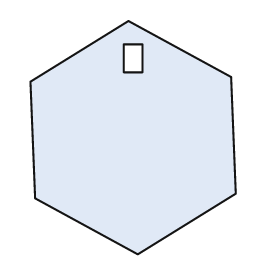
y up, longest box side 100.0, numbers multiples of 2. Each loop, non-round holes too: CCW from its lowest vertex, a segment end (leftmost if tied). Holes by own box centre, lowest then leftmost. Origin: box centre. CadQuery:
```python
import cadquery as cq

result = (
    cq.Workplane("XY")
    .moveTo(2.0, -50.0)
    .lineTo(44.0, -24.0)
    .lineTo(42.0, 26.0)
    .lineTo(-2.0, 50.0)
    .lineTo(-44.0, 24.0)
    .lineTo(-42.0, -26.0)
    .close()
    .moveTo(-4.0, 28.0)
    .lineTo(4.0, 28.0)
    .lineTo(4.0, 40.0)
    .lineTo(-4.0, 40.0)
    .close()
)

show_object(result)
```